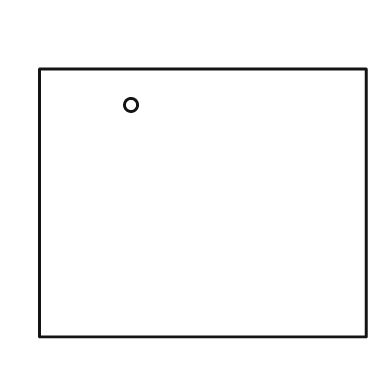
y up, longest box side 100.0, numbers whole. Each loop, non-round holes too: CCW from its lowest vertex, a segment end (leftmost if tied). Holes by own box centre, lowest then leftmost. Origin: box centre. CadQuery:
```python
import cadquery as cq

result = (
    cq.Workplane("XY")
    .moveTo(-50.0, -41.0)
    .lineTo(50.0, -41.0)
    .lineTo(50.0, 41.0)
    .lineTo(-50.0, 41.0)
    .close()
    .moveTo(-22.0, 30.0)
    .circle(2.0)
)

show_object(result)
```